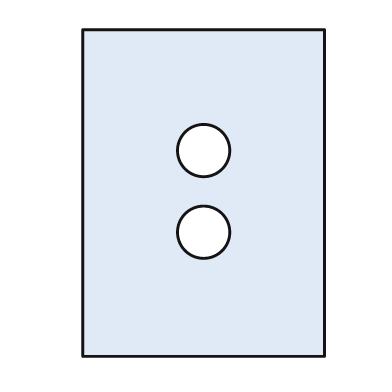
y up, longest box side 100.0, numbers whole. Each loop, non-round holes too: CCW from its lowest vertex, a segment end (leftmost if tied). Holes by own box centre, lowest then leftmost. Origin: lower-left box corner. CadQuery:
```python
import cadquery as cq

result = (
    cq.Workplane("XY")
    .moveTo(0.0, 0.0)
    .lineTo(74.0, 0.0)
    .lineTo(74.0, 100.0)
    .lineTo(0.0, 100.0)
    .close()
    .moveTo(37.0, 38.0)
    .circle(8.0)
    .moveTo(37.0, 63.0)
    .circle(8.0)
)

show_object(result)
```